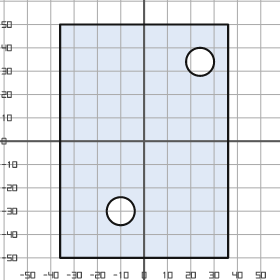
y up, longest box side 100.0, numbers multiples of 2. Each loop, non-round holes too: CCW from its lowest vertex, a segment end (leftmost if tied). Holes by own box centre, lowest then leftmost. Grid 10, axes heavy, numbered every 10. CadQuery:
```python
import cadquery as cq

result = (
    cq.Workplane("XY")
    .moveTo(-36.0, -50.0)
    .lineTo(36.0, -50.0)
    .lineTo(36.0, 50.0)
    .lineTo(-36.0, 50.0)
    .close()
    .moveTo(-10.0, -30.0)
    .circle(6.0)
    .moveTo(24.0, 34.0)
    .circle(6.0)
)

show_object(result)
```